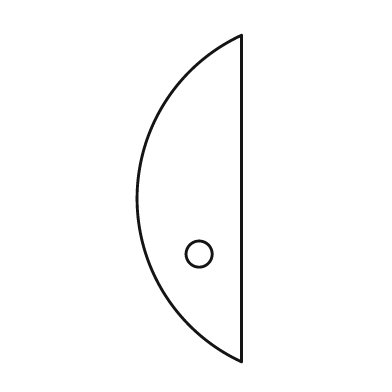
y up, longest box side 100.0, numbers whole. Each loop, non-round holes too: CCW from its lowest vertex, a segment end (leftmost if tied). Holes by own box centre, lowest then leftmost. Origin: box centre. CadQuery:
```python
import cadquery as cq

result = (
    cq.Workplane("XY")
    .moveTo(16.0, -50.0)
    .lineTo(16.0, 50.0)
    .threePointArc((-16.0, 0.0), (16.0, -50.0))
    .close()
    .moveTo(3.0, -17.0)
    .circle(4.0)
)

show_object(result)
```